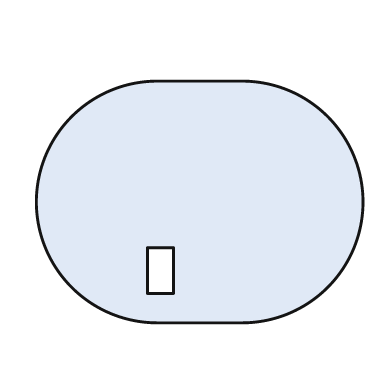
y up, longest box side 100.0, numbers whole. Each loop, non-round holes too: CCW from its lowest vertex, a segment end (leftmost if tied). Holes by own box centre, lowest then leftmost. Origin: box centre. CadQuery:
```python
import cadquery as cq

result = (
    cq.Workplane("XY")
    .moveTo(-13.0, -37.0)
    .lineTo(13.0, -37.0)
    .threePointArc((50.0, 0.0), (13.0, 37.0))
    .lineTo(-13.0, 37.0)
    .threePointArc((-50.0, 0.0), (-13.0, -37.0))
    .close()
    .moveTo(-16.0, -28.0)
    .lineTo(-8.0, -28.0)
    .lineTo(-8.0, -14.0)
    .lineTo(-16.0, -14.0)
    .close()
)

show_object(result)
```